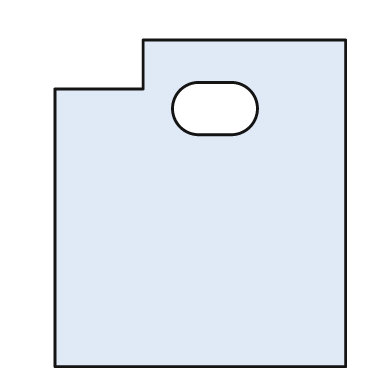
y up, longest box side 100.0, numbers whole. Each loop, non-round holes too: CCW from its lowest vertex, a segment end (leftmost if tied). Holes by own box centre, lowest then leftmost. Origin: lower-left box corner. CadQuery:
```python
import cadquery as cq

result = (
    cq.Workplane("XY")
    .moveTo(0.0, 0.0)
    .lineTo(89.0, 0.0)
    .lineTo(89.0, 100.0)
    .lineTo(27.0, 100.0)
    .lineTo(27.0, 85.0)
    .lineTo(0.0, 85.0)
    .close()
    .moveTo(44.0, 71.0)
    .lineTo(54.0, 71.0)
    .threePointArc((62.0, 79.0), (54.0, 87.0))
    .lineTo(44.0, 87.0)
    .threePointArc((36.0, 79.0), (44.0, 71.0))
    .close()
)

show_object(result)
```